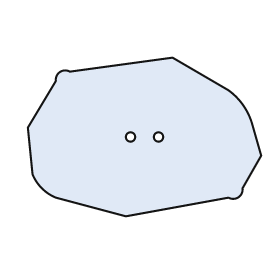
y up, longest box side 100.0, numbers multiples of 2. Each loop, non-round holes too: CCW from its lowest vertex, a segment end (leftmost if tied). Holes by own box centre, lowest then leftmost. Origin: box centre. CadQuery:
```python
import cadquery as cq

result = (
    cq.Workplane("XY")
    .moveTo(-8.0, -34.0)
    .lineTo(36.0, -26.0)
    .threePointArc((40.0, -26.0), (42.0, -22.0))
    .lineTo(50.0, -8.0)
    .lineTo(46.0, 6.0)
    .threePointArc((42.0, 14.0), (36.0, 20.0))
    .lineTo(12.0, 34.0)
    .lineTo(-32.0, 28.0)
    .threePointArc((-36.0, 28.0), (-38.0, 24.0))
    .lineTo(-50.0, 4.0)
    .lineTo(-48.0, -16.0)
    .threePointArc((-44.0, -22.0), (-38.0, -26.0))
    .close()
    .moveTo(-6.0, 0.0)
    .circle(2.0)
    .moveTo(6.0, 0.0)
    .circle(2.0)
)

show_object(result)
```